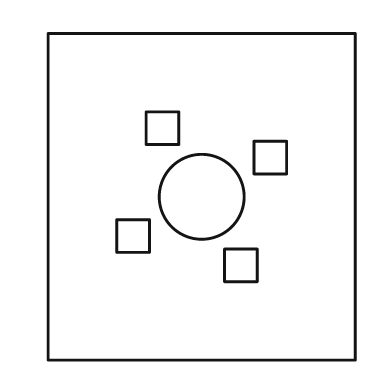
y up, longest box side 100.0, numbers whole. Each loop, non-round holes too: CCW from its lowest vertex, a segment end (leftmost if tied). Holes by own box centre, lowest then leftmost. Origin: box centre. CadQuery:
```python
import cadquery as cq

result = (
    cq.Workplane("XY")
    .moveTo(-47.0, -50.0)
    .lineTo(47.0, -50.0)
    .lineTo(47.0, 50.0)
    .lineTo(-47.0, 50.0)
    .close()
    .moveTo(7.0, -26.0)
    .lineTo(17.0, -26.0)
    .lineTo(17.0, -16.0)
    .lineTo(7.0, -16.0)
    .close()
    .moveTo(-26.0, -17.0)
    .lineTo(-16.0, -17.0)
    .lineTo(-16.0, -7.0)
    .lineTo(-26.0, -7.0)
    .close()
    .moveTo(0.0, 0.0)
    .circle(13.0)
    .moveTo(16.0, 7.0)
    .lineTo(26.0, 7.0)
    .lineTo(26.0, 17.0)
    .lineTo(16.0, 17.0)
    .close()
    .moveTo(-17.0, 16.0)
    .lineTo(-7.0, 16.0)
    .lineTo(-7.0, 26.0)
    .lineTo(-17.0, 26.0)
    .close()
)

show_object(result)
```